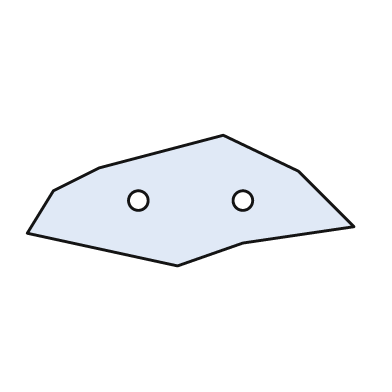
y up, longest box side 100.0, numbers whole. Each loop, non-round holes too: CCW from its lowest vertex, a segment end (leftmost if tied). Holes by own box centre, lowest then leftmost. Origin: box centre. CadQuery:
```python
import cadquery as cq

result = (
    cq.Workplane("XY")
    .moveTo(-4.0, -20.0)
    .lineTo(16.0, -13.0)
    .lineTo(50.0, -8.0)
    .lineTo(33.0, 9.0)
    .lineTo(10.0, 20.0)
    .lineTo(-28.0, 10.0)
    .lineTo(-42.0, 3.0)
    .lineTo(-50.0, -10.0)
    .close()
    .moveTo(-16.0, 0.0)
    .circle(3.0)
    .moveTo(16.0, 0.0)
    .circle(3.0)
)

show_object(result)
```